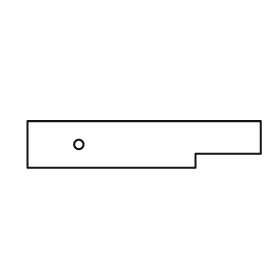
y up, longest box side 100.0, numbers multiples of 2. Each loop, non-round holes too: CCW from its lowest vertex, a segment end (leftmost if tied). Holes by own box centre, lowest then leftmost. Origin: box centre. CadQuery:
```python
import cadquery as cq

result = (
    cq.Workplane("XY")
    .moveTo(-50.0, -10.0)
    .lineTo(22.0, -10.0)
    .lineTo(22.0, -4.0)
    .lineTo(50.0, -4.0)
    .lineTo(50.0, 10.0)
    .lineTo(-50.0, 10.0)
    .close()
    .moveTo(-28.0, 0.0)
    .circle(2.0)
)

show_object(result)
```